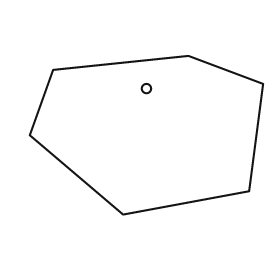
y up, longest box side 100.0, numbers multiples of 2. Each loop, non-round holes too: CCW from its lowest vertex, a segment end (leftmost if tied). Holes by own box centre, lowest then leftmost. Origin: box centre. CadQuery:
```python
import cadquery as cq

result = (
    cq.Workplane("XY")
    .moveTo(-10.0, -34.0)
    .lineTo(44.0, -24.0)
    .lineTo(50.0, 22.0)
    .lineTo(18.0, 34.0)
    .lineTo(-40.0, 28.0)
    .lineTo(-50.0, 0.0)
    .close()
    .moveTo(0.0, 20.0)
    .circle(2.0)
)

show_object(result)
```